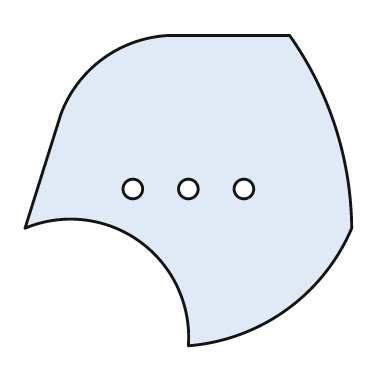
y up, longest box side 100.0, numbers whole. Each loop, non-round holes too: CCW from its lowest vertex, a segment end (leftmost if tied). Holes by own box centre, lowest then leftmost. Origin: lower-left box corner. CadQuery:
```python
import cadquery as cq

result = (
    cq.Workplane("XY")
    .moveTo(50.0, 0.0)
    .threePointArc((80.0, 11.0), (100.0, 36.0))
    .threePointArc((95.0, 67.0), (81.0, 95.0))
    .lineTo(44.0, 95.0)
    .threePointArc((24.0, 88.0), (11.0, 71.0))
    .lineTo(0.0, 36.0)
    .threePointArc((35.0, 32.0), (50.0, 0.0))
    .close()
    .moveTo(33.0, 48.0)
    .circle(3.0)
    .moveTo(50.0, 48.0)
    .circle(3.0)
    .moveTo(67.0, 48.0)
    .circle(3.0)
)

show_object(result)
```